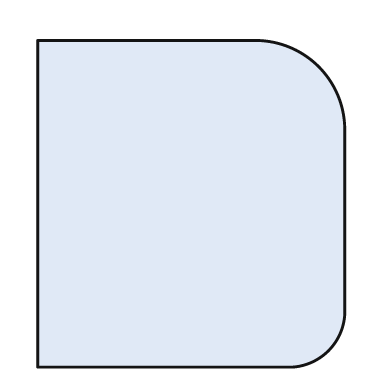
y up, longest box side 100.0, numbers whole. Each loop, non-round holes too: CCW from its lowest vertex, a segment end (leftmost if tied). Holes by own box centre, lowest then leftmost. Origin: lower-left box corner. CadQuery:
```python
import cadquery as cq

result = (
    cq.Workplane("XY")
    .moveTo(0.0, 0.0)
    .lineTo(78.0, 0.0)
    .threePointArc((89.0, 5.0), (94.0, 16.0))
    .lineTo(94.0, 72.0)
    .threePointArc((86.0, 92.0), (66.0, 100.0))
    .lineTo(0.0, 100.0)
    .close()
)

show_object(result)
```